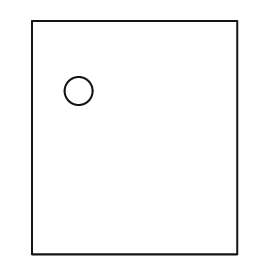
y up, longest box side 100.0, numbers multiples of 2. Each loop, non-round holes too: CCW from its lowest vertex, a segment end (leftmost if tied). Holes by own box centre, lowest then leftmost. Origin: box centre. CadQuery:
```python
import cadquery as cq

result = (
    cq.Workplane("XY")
    .moveTo(-44.0, -50.0)
    .lineTo(44.0, -50.0)
    .lineTo(44.0, 50.0)
    .lineTo(-44.0, 50.0)
    .close()
    .moveTo(-24.0, 20.0)
    .circle(6.0)
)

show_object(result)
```